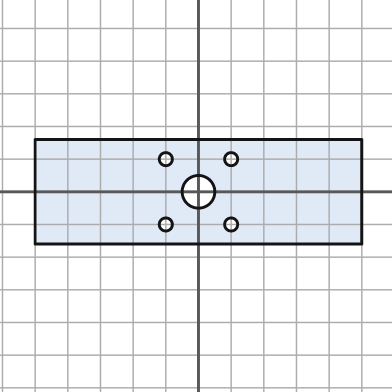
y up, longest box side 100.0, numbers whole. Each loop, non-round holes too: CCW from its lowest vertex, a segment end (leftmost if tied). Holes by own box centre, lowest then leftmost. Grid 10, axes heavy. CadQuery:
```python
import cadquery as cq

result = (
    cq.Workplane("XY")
    .moveTo(-50.0, -16.0)
    .lineTo(50.0, -16.0)
    .lineTo(50.0, 16.0)
    .lineTo(-50.0, 16.0)
    .close()
    .moveTo(-10.0, -10.0)
    .circle(2.0)
    .moveTo(10.0, -10.0)
    .circle(2.0)
    .moveTo(0.0, 0.0)
    .circle(5.0)
    .moveTo(-10.0, 10.0)
    .circle(2.0)
    .moveTo(10.0, 10.0)
    .circle(2.0)
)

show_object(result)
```